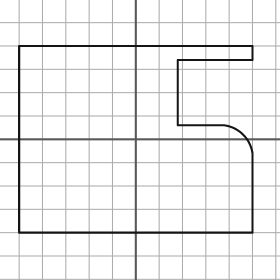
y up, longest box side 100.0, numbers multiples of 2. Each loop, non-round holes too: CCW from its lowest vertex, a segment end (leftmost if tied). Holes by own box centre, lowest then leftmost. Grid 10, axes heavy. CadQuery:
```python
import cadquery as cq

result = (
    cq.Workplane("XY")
    .moveTo(-50.0, -40.0)
    .lineTo(50.0, -40.0)
    .lineTo(50.0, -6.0)
    .threePointArc((46.0, 2.0), (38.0, 6.0))
    .lineTo(18.0, 6.0)
    .lineTo(18.0, 34.0)
    .lineTo(50.0, 34.0)
    .lineTo(50.0, 40.0)
    .lineTo(-50.0, 40.0)
    .close()
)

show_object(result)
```